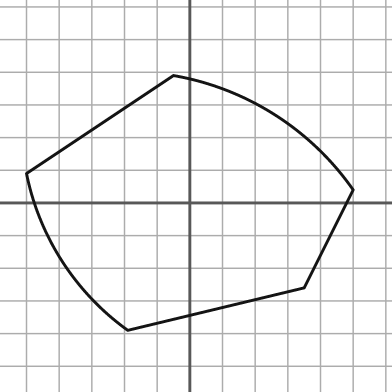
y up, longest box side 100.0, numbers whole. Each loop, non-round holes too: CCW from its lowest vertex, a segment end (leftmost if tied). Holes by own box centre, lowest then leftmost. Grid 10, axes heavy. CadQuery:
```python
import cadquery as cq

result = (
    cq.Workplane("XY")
    .moveTo(-19.0, -39.0)
    .lineTo(35.0, -26.0)
    .lineTo(50.0, 4.0)
    .threePointArc((26.0, 27.0), (-5.0, 39.0))
    .lineTo(-50.0, 9.0)
    .threePointArc((-39.0, -18.0), (-19.0, -39.0))
    .close()
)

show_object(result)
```